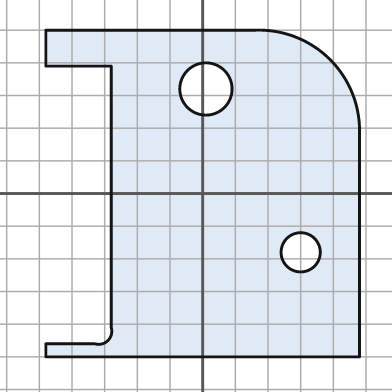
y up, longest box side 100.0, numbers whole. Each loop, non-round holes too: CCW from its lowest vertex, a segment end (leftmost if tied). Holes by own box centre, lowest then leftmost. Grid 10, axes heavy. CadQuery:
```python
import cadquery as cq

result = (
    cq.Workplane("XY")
    .moveTo(-48.0, -50.0)
    .lineTo(48.0, -50.0)
    .lineTo(48.0, 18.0)
    .threePointArc((39.0, 41.0), (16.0, 50.0))
    .lineTo(-48.0, 50.0)
    .lineTo(-48.0, 39.0)
    .lineTo(-28.0, 39.0)
    .lineTo(-28.0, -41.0)
    .threePointArc((-29.0, -45.0), (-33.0, -46.0))
    .lineTo(-48.0, -46.0)
    .close()
    .moveTo(30.0, -18.0)
    .circle(6.0)
    .moveTo(1.0, 32.0)
    .circle(8.0)
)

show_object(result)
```